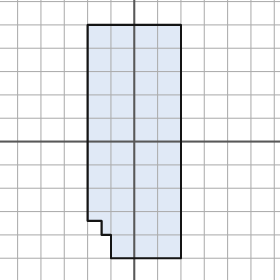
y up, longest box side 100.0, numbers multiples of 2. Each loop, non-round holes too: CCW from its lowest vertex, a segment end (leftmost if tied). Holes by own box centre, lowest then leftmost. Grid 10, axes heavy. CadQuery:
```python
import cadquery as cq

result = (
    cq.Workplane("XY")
    .moveTo(-10.0, -50.0)
    .lineTo(20.0, -50.0)
    .lineTo(20.0, 50.0)
    .lineTo(-20.0, 50.0)
    .lineTo(-20.0, -34.0)
    .lineTo(-14.0, -34.0)
    .lineTo(-14.0, -40.0)
    .lineTo(-10.0, -40.0)
    .close()
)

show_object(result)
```